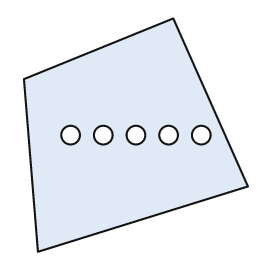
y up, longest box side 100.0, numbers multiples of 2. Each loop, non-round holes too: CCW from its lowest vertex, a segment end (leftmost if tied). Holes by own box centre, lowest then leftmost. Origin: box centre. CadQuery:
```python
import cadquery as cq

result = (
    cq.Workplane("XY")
    .moveTo(-42.0, -50.0)
    .lineTo(48.0, -22.0)
    .lineTo(16.0, 50.0)
    .lineTo(-48.0, 24.0)
    .close()
    .moveTo(-28.0, 0.0)
    .circle(4.0)
    .moveTo(-14.0, 0.0)
    .circle(4.0)
    .moveTo(0.0, 0.0)
    .circle(4.0)
    .moveTo(14.0, 0.0)
    .circle(4.0)
    .moveTo(28.0, 0.0)
    .circle(4.0)
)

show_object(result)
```